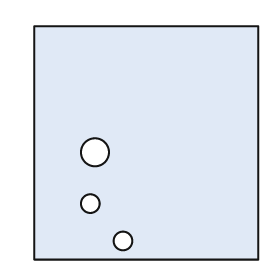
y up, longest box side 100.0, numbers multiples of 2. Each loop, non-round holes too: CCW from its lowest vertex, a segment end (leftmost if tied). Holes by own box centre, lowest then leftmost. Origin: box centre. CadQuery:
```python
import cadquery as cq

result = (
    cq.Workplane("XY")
    .moveTo(-48.0, -50.0)
    .lineTo(48.0, -50.0)
    .lineTo(48.0, 50.0)
    .lineTo(-48.0, 50.0)
    .close()
    .moveTo(-10.0, -42.0)
    .circle(4.0)
    .moveTo(-24.0, -26.0)
    .circle(4.0)
    .moveTo(-22.0, -4.0)
    .circle(6.0)
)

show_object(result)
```